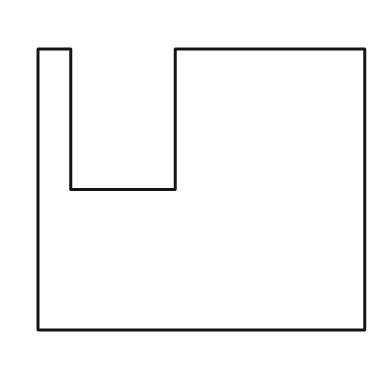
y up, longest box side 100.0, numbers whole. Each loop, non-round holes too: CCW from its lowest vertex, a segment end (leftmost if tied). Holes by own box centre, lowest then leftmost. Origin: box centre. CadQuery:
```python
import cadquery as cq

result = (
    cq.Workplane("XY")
    .moveTo(-50.0, -43.0)
    .lineTo(50.0, -43.0)
    .lineTo(50.0, 43.0)
    .lineTo(-8.0, 43.0)
    .lineTo(-8.0, 0.0)
    .lineTo(-40.0, 0.0)
    .lineTo(-40.0, 43.0)
    .lineTo(-50.0, 43.0)
    .close()
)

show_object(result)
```